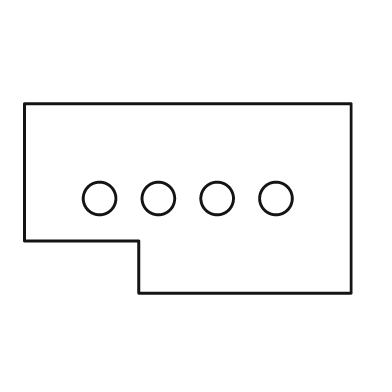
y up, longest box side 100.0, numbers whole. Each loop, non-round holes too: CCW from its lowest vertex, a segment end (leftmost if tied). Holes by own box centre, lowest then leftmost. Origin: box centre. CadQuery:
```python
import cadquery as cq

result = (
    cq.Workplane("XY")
    .moveTo(-15.0, -29.0)
    .lineTo(50.0, -29.0)
    .lineTo(50.0, 29.0)
    .lineTo(-50.0, 29.0)
    .lineTo(-50.0, -13.0)
    .lineTo(-15.0, -13.0)
    .close()
    .moveTo(-27.0, 0.0)
    .circle(5.0)
    .moveTo(-9.0, 0.0)
    .circle(5.0)
    .moveTo(9.0, 0.0)
    .circle(5.0)
    .moveTo(27.0, 0.0)
    .circle(5.0)
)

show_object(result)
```